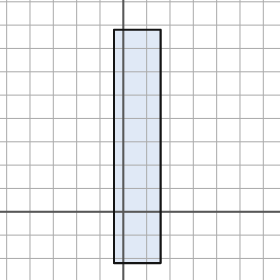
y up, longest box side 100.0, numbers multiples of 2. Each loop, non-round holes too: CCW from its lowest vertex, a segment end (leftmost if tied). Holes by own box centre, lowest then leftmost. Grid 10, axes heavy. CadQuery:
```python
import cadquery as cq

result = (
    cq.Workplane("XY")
    .moveTo(-4.0, -22.0)
    .lineTo(16.0, -22.0)
    .lineTo(16.0, 78.0)
    .lineTo(-4.0, 78.0)
    .close()
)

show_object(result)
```